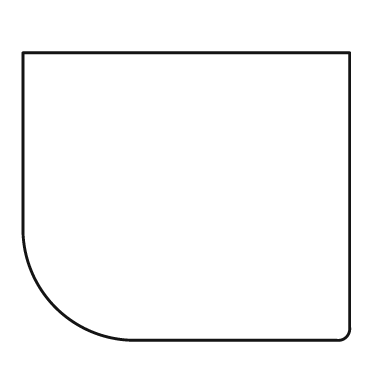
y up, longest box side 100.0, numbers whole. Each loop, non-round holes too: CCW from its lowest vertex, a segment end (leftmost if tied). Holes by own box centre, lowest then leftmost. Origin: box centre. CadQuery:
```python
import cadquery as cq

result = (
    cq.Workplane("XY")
    .moveTo(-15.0, -44.0)
    .lineTo(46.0, -44.0)
    .threePointArc((49.0, -43.0), (50.0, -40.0))
    .lineTo(50.0, 44.0)
    .lineTo(-50.0, 44.0)
    .lineTo(-50.0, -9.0)
    .threePointArc((-40.0, -34.0), (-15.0, -44.0))
    .close()
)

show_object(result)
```